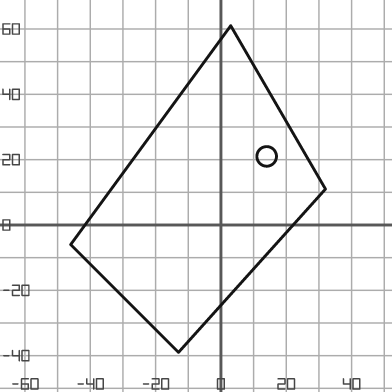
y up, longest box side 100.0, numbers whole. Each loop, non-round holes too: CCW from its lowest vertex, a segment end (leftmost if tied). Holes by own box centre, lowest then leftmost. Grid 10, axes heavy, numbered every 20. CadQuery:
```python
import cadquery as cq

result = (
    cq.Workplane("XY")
    .moveTo(-13.0, -39.0)
    .lineTo(32.0, 11.0)
    .lineTo(3.0, 61.0)
    .lineTo(-46.0, -6.0)
    .close()
    .moveTo(14.0, 21.0)
    .circle(3.0)
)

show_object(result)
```